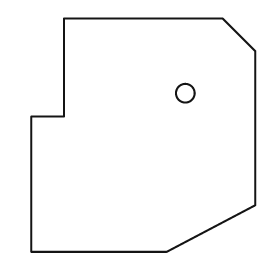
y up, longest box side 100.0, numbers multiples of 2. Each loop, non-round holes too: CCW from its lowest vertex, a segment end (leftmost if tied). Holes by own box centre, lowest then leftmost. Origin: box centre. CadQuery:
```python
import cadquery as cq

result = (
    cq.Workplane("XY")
    .moveTo(-48.0, -50.0)
    .lineTo(10.0, -50.0)
    .lineTo(48.0, -30.0)
    .lineTo(48.0, 36.0)
    .lineTo(34.0, 50.0)
    .lineTo(-34.0, 50.0)
    .lineTo(-34.0, 8.0)
    .lineTo(-48.0, 8.0)
    .close()
    .moveTo(18.0, 18.0)
    .circle(4.0)
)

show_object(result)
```